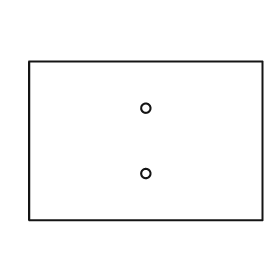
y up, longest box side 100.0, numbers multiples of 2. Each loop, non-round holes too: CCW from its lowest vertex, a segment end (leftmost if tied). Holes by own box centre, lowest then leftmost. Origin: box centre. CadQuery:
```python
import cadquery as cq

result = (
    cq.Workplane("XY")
    .moveTo(-50.0, -34.0)
    .lineTo(50.0, -34.0)
    .lineTo(50.0, 34.0)
    .lineTo(-50.0, 34.0)
    .close()
    .moveTo(0.0, -14.0)
    .circle(2.0)
    .moveTo(0.0, 14.0)
    .circle(2.0)
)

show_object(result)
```